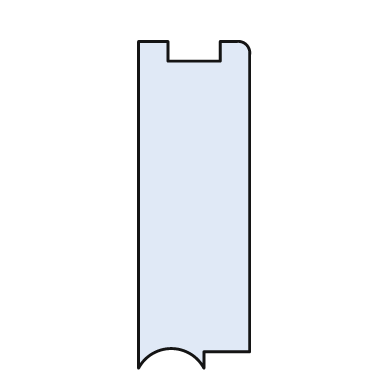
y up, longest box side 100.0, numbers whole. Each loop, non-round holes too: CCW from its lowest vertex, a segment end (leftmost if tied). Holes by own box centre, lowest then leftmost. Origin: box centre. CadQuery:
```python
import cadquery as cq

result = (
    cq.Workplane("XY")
    .moveTo(-17.0, -50.0)
    .threePointArc((-7.0, -44.0), (3.0, -50.0))
    .lineTo(3.0, -45.0)
    .lineTo(17.0, -45.0)
    .lineTo(17.0, 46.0)
    .threePointArc((16.0, 49.0), (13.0, 50.0))
    .lineTo(8.0, 50.0)
    .lineTo(8.0, 44.0)
    .lineTo(-8.0, 44.0)
    .lineTo(-8.0, 50.0)
    .lineTo(-17.0, 50.0)
    .close()
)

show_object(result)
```